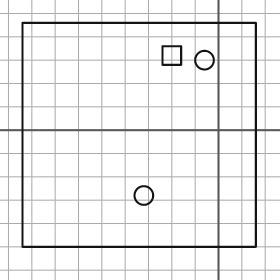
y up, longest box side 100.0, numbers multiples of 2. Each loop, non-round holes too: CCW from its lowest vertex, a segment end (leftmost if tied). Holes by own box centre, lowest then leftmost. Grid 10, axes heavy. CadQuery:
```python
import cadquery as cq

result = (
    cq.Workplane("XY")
    .moveTo(-84.0, -50.0)
    .lineTo(16.0, -50.0)
    .lineTo(16.0, 46.0)
    .lineTo(-84.0, 46.0)
    .close()
    .moveTo(-32.0, -28.0)
    .circle(4.0)
    .moveTo(-6.0, 30.0)
    .circle(4.0)
    .moveTo(-24.0, 28.0)
    .lineTo(-16.0, 28.0)
    .lineTo(-16.0, 36.0)
    .lineTo(-24.0, 36.0)
    .close()
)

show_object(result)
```